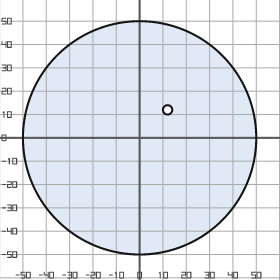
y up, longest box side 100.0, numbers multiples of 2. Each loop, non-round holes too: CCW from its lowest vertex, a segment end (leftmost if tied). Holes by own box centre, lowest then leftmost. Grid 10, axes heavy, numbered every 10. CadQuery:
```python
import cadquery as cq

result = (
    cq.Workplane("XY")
    .moveTo(0.0, 0.0)
    .circle(50.0)
    .moveTo(12.0, 12.0)
    .circle(2.0)
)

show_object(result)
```